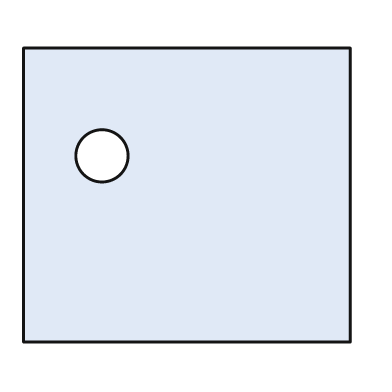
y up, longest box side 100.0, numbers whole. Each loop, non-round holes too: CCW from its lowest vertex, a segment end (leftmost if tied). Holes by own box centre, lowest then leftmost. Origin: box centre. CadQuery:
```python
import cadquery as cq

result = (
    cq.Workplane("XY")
    .moveTo(-50.0, -45.0)
    .lineTo(50.0, -45.0)
    .lineTo(50.0, 45.0)
    .lineTo(-50.0, 45.0)
    .close()
    .moveTo(-26.0, 12.0)
    .circle(8.0)
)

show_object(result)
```